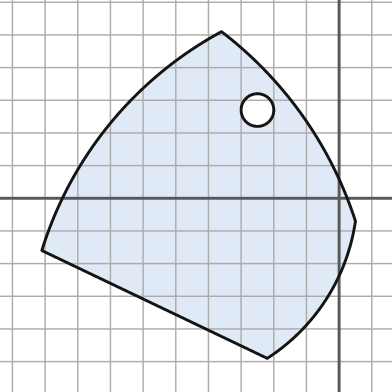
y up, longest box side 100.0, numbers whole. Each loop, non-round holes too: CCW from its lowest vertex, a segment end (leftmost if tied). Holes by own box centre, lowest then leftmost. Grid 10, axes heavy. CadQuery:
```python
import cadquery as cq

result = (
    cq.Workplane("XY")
    .moveTo(-22.0, -49.0)
    .threePointArc((-4.0, -31.0), (5.0, -7.0))
    .threePointArc((-11.0, 25.0), (-36.0, 51.0))
    .threePointArc((-70.0, 23.0), (-91.0, -16.0))
    .close()
    .moveTo(-25.0, 27.0)
    .circle(5.0)
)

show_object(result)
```